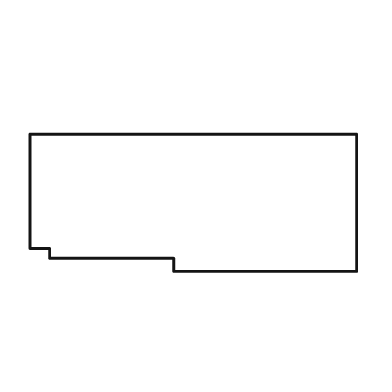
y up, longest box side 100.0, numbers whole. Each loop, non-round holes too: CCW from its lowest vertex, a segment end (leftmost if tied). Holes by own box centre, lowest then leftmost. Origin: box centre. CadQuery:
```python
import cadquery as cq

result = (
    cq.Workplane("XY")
    .moveTo(-6.0, -21.0)
    .lineTo(50.0, -21.0)
    .lineTo(50.0, 21.0)
    .lineTo(-50.0, 21.0)
    .lineTo(-50.0, -14.0)
    .lineTo(-44.0, -14.0)
    .lineTo(-44.0, -17.0)
    .lineTo(-6.0, -17.0)
    .close()
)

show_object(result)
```